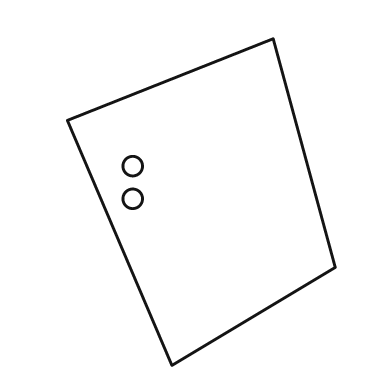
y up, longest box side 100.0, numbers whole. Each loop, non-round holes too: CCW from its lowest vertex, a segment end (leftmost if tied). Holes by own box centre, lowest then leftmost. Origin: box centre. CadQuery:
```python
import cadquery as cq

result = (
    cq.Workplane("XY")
    .moveTo(-9.0, -50.0)
    .lineTo(41.0, -20.0)
    .lineTo(22.0, 50.0)
    .lineTo(-41.0, 25.0)
    .close()
    .moveTo(-21.0, 1.0)
    .circle(3.0)
    .moveTo(-21.0, 11.0)
    .circle(3.0)
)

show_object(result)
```